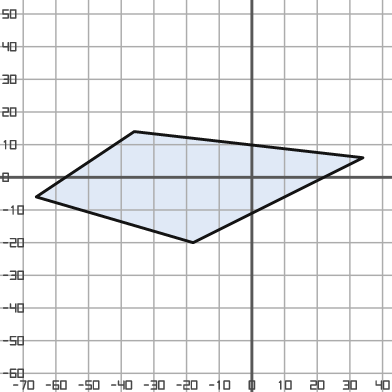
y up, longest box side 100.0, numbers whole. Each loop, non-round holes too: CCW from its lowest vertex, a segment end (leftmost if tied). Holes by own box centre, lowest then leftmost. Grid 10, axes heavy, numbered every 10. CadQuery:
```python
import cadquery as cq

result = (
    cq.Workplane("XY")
    .moveTo(-18.0, -20.0)
    .lineTo(34.0, 6.0)
    .lineTo(-36.0, 14.0)
    .lineTo(-66.0, -6.0)
    .close()
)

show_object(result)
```